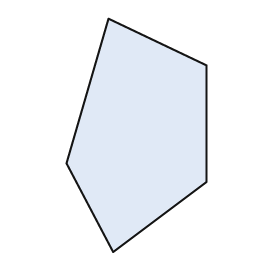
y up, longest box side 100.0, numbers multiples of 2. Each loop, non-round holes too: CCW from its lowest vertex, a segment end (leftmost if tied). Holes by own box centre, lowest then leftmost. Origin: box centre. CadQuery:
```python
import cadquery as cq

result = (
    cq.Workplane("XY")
    .moveTo(-10.0, -50.0)
    .lineTo(30.0, -20.0)
    .lineTo(30.0, 30.0)
    .lineTo(-12.0, 50.0)
    .lineTo(-30.0, -12.0)
    .close()
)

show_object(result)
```